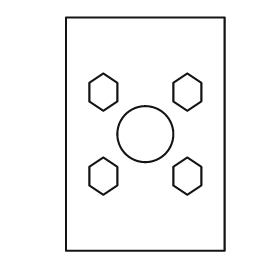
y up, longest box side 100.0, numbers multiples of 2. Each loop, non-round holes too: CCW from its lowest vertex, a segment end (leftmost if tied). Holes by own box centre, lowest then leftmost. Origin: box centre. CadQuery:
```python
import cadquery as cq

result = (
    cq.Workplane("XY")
    .moveTo(-34.0, -50.0)
    .lineTo(34.0, -50.0)
    .lineTo(34.0, 50.0)
    .lineTo(-34.0, 50.0)
    .close()
    .moveTo(-18.0, -26.0)
    .lineTo(-12.0, -22.0)
    .lineTo(-12.0, -14.0)
    .lineTo(-18.0, -10.0)
    .lineTo(-24.0, -14.0)
    .lineTo(-24.0, -22.0)
    .close()
    .moveTo(18.0, -26.0)
    .lineTo(24.0, -22.0)
    .lineTo(24.0, -14.0)
    .lineTo(18.0, -10.0)
    .lineTo(12.0, -14.0)
    .lineTo(12.0, -22.0)
    .close()
    .moveTo(0.0, 0.0)
    .circle(12.0)
    .moveTo(-18.0, 10.0)
    .lineTo(-12.0, 14.0)
    .lineTo(-12.0, 22.0)
    .lineTo(-18.0, 26.0)
    .lineTo(-24.0, 22.0)
    .lineTo(-24.0, 14.0)
    .close()
    .moveTo(18.0, 10.0)
    .lineTo(24.0, 14.0)
    .lineTo(24.0, 22.0)
    .lineTo(18.0, 26.0)
    .lineTo(12.0, 22.0)
    .lineTo(12.0, 14.0)
    .close()
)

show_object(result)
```